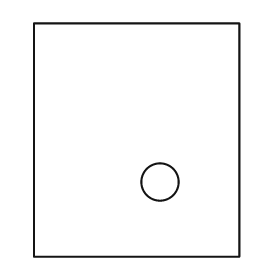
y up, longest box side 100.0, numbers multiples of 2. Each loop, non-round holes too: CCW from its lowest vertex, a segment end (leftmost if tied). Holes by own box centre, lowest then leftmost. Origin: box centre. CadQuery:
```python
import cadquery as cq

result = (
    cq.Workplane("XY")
    .moveTo(-44.0, -50.0)
    .lineTo(44.0, -50.0)
    .lineTo(44.0, 50.0)
    .lineTo(-44.0, 50.0)
    .close()
    .moveTo(10.0, -18.0)
    .circle(8.0)
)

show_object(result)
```